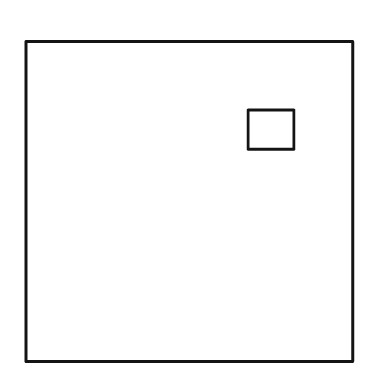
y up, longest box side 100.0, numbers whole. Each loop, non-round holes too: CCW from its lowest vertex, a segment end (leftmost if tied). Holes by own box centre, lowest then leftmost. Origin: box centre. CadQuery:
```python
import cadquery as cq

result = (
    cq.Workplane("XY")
    .moveTo(-50.0, -49.0)
    .lineTo(50.0, -49.0)
    .lineTo(50.0, 49.0)
    .lineTo(-50.0, 49.0)
    .close()
    .moveTo(18.0, 16.0)
    .lineTo(32.0, 16.0)
    .lineTo(32.0, 28.0)
    .lineTo(18.0, 28.0)
    .close()
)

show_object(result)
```